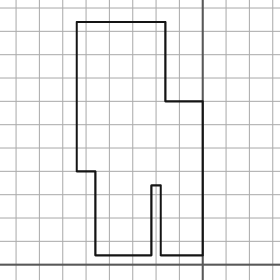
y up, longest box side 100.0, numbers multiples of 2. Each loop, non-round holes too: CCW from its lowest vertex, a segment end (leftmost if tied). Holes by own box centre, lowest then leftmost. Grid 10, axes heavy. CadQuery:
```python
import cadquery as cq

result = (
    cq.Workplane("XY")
    .moveTo(-46.0, 4.0)
    .lineTo(-22.0, 4.0)
    .lineTo(-22.0, 34.0)
    .lineTo(-18.0, 34.0)
    .lineTo(-18.0, 4.0)
    .lineTo(0.0, 4.0)
    .lineTo(0.0, 70.0)
    .lineTo(-16.0, 70.0)
    .lineTo(-16.0, 104.0)
    .lineTo(-54.0, 104.0)
    .lineTo(-54.0, 40.0)
    .lineTo(-46.0, 40.0)
    .close()
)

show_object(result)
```